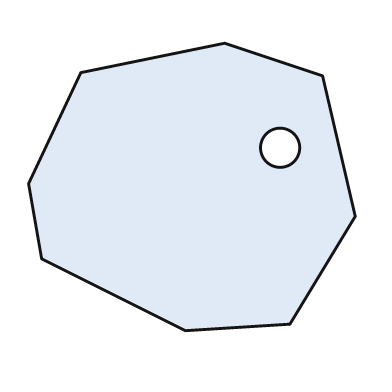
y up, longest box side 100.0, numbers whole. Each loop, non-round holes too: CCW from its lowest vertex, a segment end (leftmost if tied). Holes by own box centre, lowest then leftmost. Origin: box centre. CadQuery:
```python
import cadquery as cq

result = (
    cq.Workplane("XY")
    .moveTo(-2.0, -44.0)
    .lineTo(30.0, -42.0)
    .lineTo(50.0, -9.0)
    .lineTo(40.0, 34.0)
    .lineTo(10.0, 44.0)
    .lineTo(-34.0, 35.0)
    .lineTo(-50.0, 1.0)
    .lineTo(-46.0, -22.0)
    .close()
    .moveTo(27.0, 12.0)
    .circle(6.0)
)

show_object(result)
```